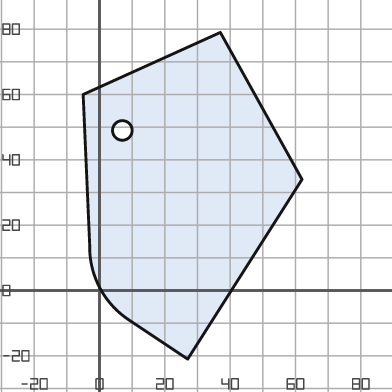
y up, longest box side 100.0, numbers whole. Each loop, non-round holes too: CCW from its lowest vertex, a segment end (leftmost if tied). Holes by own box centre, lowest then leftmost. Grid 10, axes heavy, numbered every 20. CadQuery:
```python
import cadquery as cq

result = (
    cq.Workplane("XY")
    .moveTo(27.0, -21.0)
    .lineTo(62.0, 34.0)
    .lineTo(37.0, 79.0)
    .lineTo(-5.0, 60.0)
    .lineTo(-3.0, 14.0)
    .threePointArc((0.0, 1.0), (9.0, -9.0))
    .close()
    .moveTo(7.0, 49.0)
    .circle(3.0)
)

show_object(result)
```